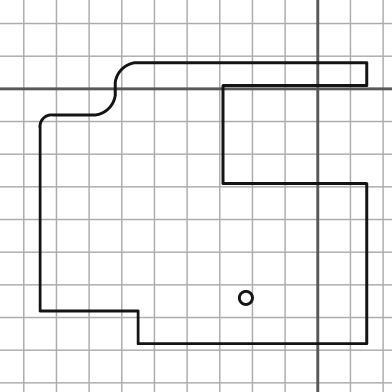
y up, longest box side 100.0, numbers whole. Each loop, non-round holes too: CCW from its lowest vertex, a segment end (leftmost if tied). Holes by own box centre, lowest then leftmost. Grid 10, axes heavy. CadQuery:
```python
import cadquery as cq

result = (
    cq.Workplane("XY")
    .moveTo(-55.0, -78.0)
    .lineTo(15.0, -78.0)
    .lineTo(15.0, -29.0)
    .lineTo(-29.0, -29.0)
    .lineTo(-29.0, 1.0)
    .lineTo(15.0, 1.0)
    .lineTo(15.0, 8.0)
    .lineTo(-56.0, 8.0)
    .threePointArc((-60.0, 6.0), (-62.0, 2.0))
    .lineTo(-62.0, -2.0)
    .threePointArc((-64.0, -6.0), (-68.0, -8.0))
    .lineTo(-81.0, -8.0)
    .threePointArc((-84.0, -9.0), (-85.0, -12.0))
    .lineTo(-85.0, -68.0)
    .lineTo(-55.0, -68.0)
    .close()
    .moveTo(-22.0, -64.0)
    .circle(2.0)
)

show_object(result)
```